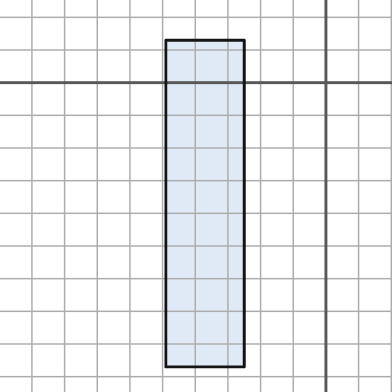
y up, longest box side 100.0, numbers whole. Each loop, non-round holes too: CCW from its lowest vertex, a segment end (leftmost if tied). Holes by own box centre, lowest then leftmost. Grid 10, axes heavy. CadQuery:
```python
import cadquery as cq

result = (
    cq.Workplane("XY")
    .moveTo(-49.0, -87.0)
    .lineTo(-25.0, -87.0)
    .lineTo(-25.0, 13.0)
    .lineTo(-49.0, 13.0)
    .close()
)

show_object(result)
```